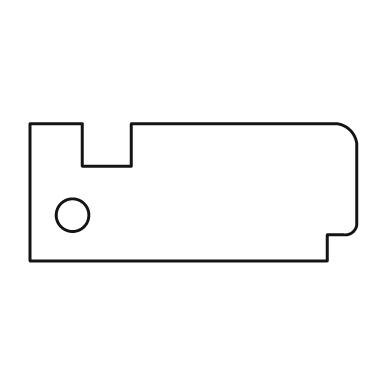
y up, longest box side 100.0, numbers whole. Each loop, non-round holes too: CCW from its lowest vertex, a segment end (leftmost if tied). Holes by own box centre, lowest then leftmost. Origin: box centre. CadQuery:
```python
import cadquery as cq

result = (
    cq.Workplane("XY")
    .moveTo(-50.0, -21.0)
    .lineTo(41.0, -21.0)
    .lineTo(41.0, -13.0)
    .lineTo(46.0, -13.0)
    .threePointArc((49.0, -12.0), (50.0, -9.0))
    .lineTo(50.0, 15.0)
    .threePointArc((48.0, 19.0), (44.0, 21.0))
    .lineTo(-19.0, 21.0)
    .lineTo(-19.0, 8.0)
    .lineTo(-34.0, 8.0)
    .lineTo(-34.0, 21.0)
    .lineTo(-50.0, 21.0)
    .close()
    .moveTo(-37.0, -7.0)
    .circle(5.0)
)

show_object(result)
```